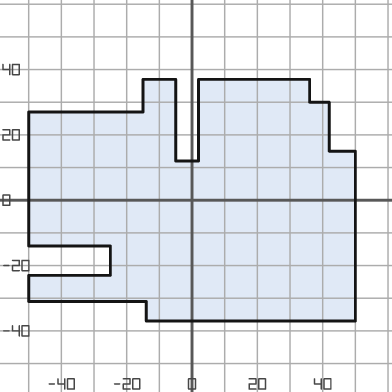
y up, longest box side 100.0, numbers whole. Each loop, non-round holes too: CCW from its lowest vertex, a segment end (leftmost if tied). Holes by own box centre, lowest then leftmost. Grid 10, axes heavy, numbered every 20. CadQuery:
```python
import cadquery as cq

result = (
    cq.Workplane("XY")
    .moveTo(-14.0, -37.0)
    .lineTo(50.0, -37.0)
    .lineTo(50.0, 15.0)
    .lineTo(42.0, 15.0)
    .lineTo(42.0, 30.0)
    .lineTo(36.0, 30.0)
    .lineTo(36.0, 37.0)
    .lineTo(2.0, 37.0)
    .lineTo(2.0, 12.0)
    .lineTo(-5.0, 12.0)
    .lineTo(-5.0, 37.0)
    .lineTo(-15.0, 37.0)
    .lineTo(-15.0, 27.0)
    .lineTo(-50.0, 27.0)
    .lineTo(-50.0, -14.0)
    .lineTo(-25.0, -14.0)
    .lineTo(-25.0, -23.0)
    .lineTo(-50.0, -23.0)
    .lineTo(-50.0, -31.0)
    .lineTo(-14.0, -31.0)
    .close()
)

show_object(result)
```